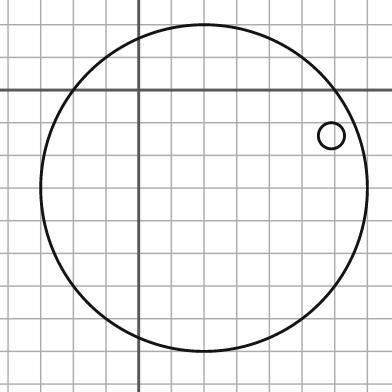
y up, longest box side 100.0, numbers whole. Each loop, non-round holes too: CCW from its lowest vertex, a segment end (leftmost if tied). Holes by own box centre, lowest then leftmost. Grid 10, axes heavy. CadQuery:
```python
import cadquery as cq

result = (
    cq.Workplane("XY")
    .moveTo(20.0, -30.0)
    .circle(50.0)
    .moveTo(59.0, -14.0)
    .circle(4.0)
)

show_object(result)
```